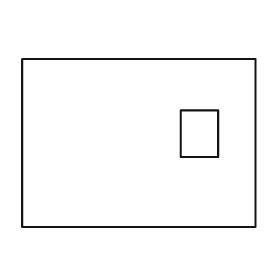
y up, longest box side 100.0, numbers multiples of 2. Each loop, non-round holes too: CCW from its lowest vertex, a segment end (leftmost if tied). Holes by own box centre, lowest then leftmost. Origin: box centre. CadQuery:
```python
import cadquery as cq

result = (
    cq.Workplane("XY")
    .moveTo(-50.0, -36.0)
    .lineTo(50.0, -36.0)
    .lineTo(50.0, 36.0)
    .lineTo(-50.0, 36.0)
    .close()
    .moveTo(18.0, -6.0)
    .lineTo(34.0, -6.0)
    .lineTo(34.0, 14.0)
    .lineTo(18.0, 14.0)
    .close()
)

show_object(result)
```